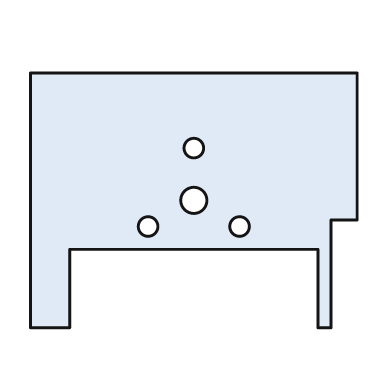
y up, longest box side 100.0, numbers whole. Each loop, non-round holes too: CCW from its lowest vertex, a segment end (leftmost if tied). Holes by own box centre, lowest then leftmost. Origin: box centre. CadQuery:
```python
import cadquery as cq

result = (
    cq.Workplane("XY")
    .moveTo(-50.0, -39.0)
    .lineTo(-38.0, -39.0)
    .lineTo(-38.0, -15.0)
    .lineTo(38.0, -15.0)
    .lineTo(38.0, -39.0)
    .lineTo(42.0, -39.0)
    .lineTo(42.0, -6.0)
    .lineTo(50.0, -6.0)
    .lineTo(50.0, 39.0)
    .lineTo(-50.0, 39.0)
    .close()
    .moveTo(-14.0, -8.0)
    .circle(3.0)
    .moveTo(14.0, -8.0)
    .circle(3.0)
    .moveTo(0.0, 0.0)
    .circle(4.0)
    .moveTo(0.0, 16.0)
    .circle(3.0)
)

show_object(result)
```